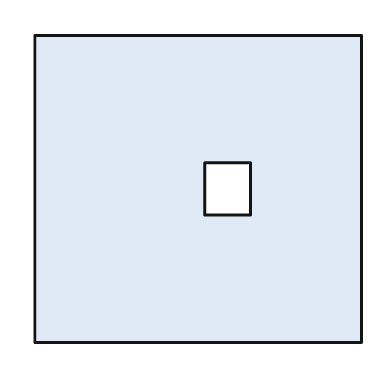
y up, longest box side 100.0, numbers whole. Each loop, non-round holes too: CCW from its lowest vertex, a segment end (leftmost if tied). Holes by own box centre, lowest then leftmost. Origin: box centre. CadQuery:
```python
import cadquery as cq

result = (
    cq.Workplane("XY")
    .moveTo(-50.0, -47.0)
    .lineTo(50.0, -47.0)
    .lineTo(50.0, 47.0)
    .lineTo(-50.0, 47.0)
    .close()
    .moveTo(2.0, -8.0)
    .lineTo(16.0, -8.0)
    .lineTo(16.0, 8.0)
    .lineTo(2.0, 8.0)
    .close()
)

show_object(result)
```